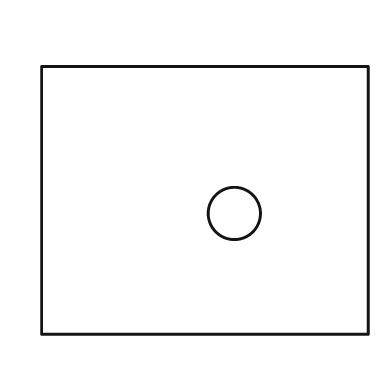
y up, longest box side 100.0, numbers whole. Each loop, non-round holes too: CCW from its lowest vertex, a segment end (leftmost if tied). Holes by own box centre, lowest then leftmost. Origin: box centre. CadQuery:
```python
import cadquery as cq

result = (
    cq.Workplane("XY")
    .moveTo(-50.0, -41.0)
    .lineTo(50.0, -41.0)
    .lineTo(50.0, 41.0)
    .lineTo(-50.0, 41.0)
    .close()
    .moveTo(9.0, -4.0)
    .circle(8.0)
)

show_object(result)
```